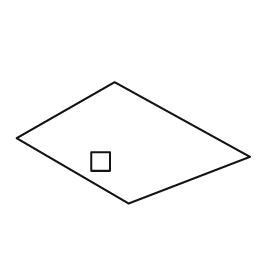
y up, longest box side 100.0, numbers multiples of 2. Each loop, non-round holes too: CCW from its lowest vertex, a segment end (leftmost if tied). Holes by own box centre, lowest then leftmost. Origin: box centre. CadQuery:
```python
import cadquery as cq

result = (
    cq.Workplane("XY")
    .moveTo(-2.0, -26.0)
    .lineTo(50.0, -6.0)
    .lineTo(-8.0, 26.0)
    .lineTo(-50.0, 2.0)
    .close()
    .moveTo(-18.0, -12.0)
    .lineTo(-10.0, -12.0)
    .lineTo(-10.0, -4.0)
    .lineTo(-18.0, -4.0)
    .close()
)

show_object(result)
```